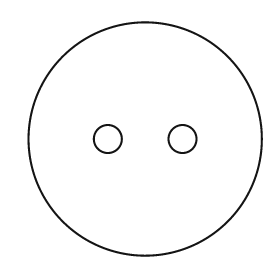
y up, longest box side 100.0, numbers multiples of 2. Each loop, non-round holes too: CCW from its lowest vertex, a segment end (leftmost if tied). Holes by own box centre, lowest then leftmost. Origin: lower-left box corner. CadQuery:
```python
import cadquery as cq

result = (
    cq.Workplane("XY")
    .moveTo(50.0, 50.0)
    .circle(50.0)
    .moveTo(34.0, 50.0)
    .circle(6.0)
    .moveTo(66.0, 50.0)
    .circle(6.0)
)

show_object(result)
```